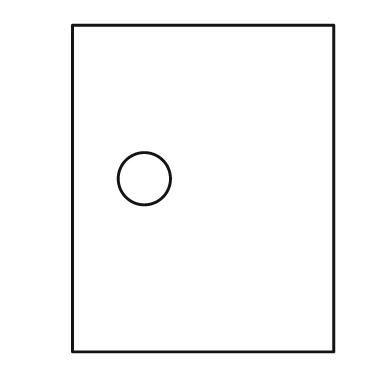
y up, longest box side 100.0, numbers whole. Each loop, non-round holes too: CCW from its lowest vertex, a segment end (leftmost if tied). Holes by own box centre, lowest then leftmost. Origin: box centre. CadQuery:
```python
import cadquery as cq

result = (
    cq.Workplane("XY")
    .moveTo(-40.0, -50.0)
    .lineTo(40.0, -50.0)
    .lineTo(40.0, 50.0)
    .lineTo(-40.0, 50.0)
    .close()
    .moveTo(-18.0, 3.0)
    .circle(8.0)
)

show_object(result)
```